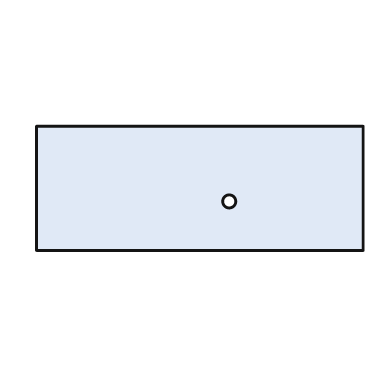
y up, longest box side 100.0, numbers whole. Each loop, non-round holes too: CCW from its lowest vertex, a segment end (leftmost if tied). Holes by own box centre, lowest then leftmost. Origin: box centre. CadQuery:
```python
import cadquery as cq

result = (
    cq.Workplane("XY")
    .moveTo(-50.0, -19.0)
    .lineTo(50.0, -19.0)
    .lineTo(50.0, 19.0)
    .lineTo(-50.0, 19.0)
    .close()
    .moveTo(9.0, -4.0)
    .circle(2.0)
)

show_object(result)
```